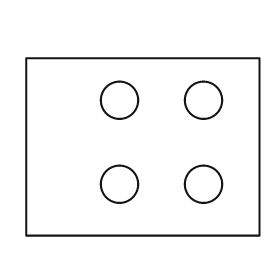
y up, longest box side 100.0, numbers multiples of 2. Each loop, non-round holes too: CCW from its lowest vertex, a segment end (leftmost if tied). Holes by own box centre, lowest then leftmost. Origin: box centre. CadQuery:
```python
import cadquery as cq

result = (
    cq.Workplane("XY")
    .moveTo(-50.0, -38.0)
    .lineTo(50.0, -38.0)
    .lineTo(50.0, 38.0)
    .lineTo(-50.0, 38.0)
    .close()
    .moveTo(-10.0, -16.0)
    .circle(8.0)
    .moveTo(26.0, -16.0)
    .circle(8.0)
    .moveTo(-10.0, 20.0)
    .circle(8.0)
    .moveTo(26.0, 20.0)
    .circle(8.0)
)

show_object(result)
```